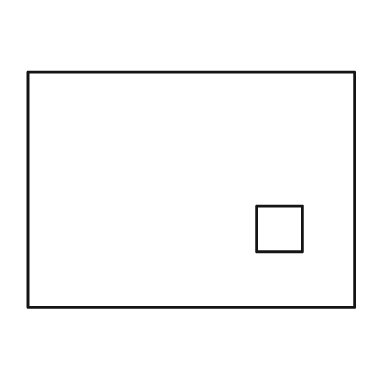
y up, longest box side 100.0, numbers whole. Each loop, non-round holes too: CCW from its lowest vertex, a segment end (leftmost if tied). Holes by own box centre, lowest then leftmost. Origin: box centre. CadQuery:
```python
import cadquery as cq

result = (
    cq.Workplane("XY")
    .moveTo(-50.0, -36.0)
    .lineTo(50.0, -36.0)
    .lineTo(50.0, 36.0)
    .lineTo(-50.0, 36.0)
    .close()
    .moveTo(20.0, -19.0)
    .lineTo(34.0, -19.0)
    .lineTo(34.0, -5.0)
    .lineTo(20.0, -5.0)
    .close()
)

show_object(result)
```